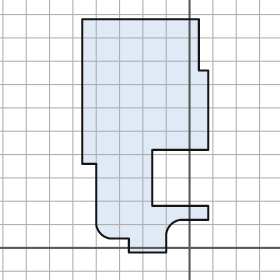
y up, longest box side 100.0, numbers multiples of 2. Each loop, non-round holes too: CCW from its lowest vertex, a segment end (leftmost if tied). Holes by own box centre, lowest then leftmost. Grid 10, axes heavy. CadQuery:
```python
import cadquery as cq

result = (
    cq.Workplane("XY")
    .moveTo(-26.0, -2.0)
    .lineTo(-10.0, -2.0)
    .lineTo(-10.0, 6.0)
    .threePointArc((-8.0, 10.0), (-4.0, 12.0))
    .lineTo(8.0, 12.0)
    .lineTo(8.0, 18.0)
    .lineTo(-16.0, 18.0)
    .lineTo(-16.0, 42.0)
    .lineTo(8.0, 42.0)
    .lineTo(8.0, 76.0)
    .lineTo(4.0, 76.0)
    .lineTo(4.0, 98.0)
    .lineTo(-46.0, 98.0)
    .lineTo(-46.0, 36.0)
    .lineTo(-40.0, 36.0)
    .lineTo(-40.0, 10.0)
    .threePointArc((-38.0, 6.0), (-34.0, 4.0))
    .lineTo(-26.0, 4.0)
    .close()
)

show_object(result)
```